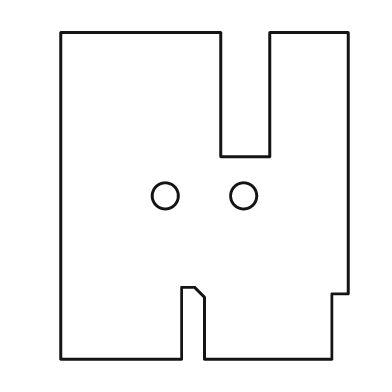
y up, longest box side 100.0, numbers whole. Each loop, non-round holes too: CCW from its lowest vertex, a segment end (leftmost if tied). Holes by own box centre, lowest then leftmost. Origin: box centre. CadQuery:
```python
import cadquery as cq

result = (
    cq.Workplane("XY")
    .moveTo(-44.0, -50.0)
    .lineTo(-7.0, -50.0)
    .lineTo(-7.0, -28.0)
    .lineTo(-3.0, -28.0)
    .lineTo(0.0, -31.0)
    .lineTo(0.0, -50.0)
    .lineTo(39.0, -50.0)
    .lineTo(39.0, -30.0)
    .lineTo(44.0, -30.0)
    .lineTo(44.0, 50.0)
    .lineTo(20.0, 50.0)
    .lineTo(20.0, 12.0)
    .lineTo(5.0, 12.0)
    .lineTo(5.0, 50.0)
    .lineTo(-44.0, 50.0)
    .close()
    .moveTo(-12.0, 0.0)
    .circle(4.0)
    .moveTo(12.0, 0.0)
    .circle(4.0)
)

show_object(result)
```